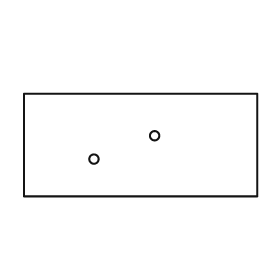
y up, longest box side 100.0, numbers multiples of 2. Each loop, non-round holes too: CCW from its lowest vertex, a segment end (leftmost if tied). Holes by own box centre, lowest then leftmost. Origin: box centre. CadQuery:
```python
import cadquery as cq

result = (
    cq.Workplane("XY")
    .moveTo(-50.0, -22.0)
    .lineTo(50.0, -22.0)
    .lineTo(50.0, 22.0)
    .lineTo(-50.0, 22.0)
    .close()
    .moveTo(-20.0, -6.0)
    .circle(2.0)
    .moveTo(6.0, 4.0)
    .circle(2.0)
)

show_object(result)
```